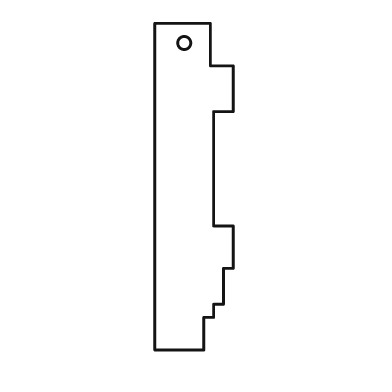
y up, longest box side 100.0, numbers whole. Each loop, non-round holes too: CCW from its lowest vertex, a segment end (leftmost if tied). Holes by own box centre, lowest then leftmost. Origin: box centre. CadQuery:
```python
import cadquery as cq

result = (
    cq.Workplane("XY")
    .moveTo(-12.0, -50.0)
    .lineTo(3.0, -50.0)
    .lineTo(3.0, -40.0)
    .lineTo(6.0, -40.0)
    .lineTo(6.0, -36.0)
    .lineTo(9.0, -36.0)
    .lineTo(9.0, -25.0)
    .lineTo(12.0, -25.0)
    .lineTo(12.0, -12.0)
    .lineTo(6.0, -12.0)
    .lineTo(6.0, 23.0)
    .lineTo(12.0, 23.0)
    .lineTo(12.0, 37.0)
    .lineTo(5.0, 37.0)
    .lineTo(5.0, 50.0)
    .lineTo(-12.0, 50.0)
    .close()
    .moveTo(-3.0, 44.0)
    .circle(2.0)
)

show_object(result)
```